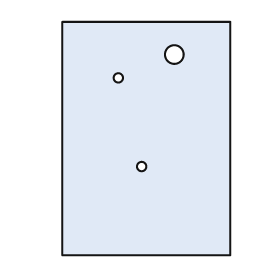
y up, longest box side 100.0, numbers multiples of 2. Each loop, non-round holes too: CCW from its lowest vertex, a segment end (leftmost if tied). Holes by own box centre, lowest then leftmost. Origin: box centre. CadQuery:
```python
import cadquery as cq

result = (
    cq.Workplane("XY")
    .moveTo(-36.0, -50.0)
    .lineTo(36.0, -50.0)
    .lineTo(36.0, 50.0)
    .lineTo(-36.0, 50.0)
    .close()
    .moveTo(-2.0, -12.0)
    .circle(2.0)
    .moveTo(-12.0, 26.0)
    .circle(2.0)
    .moveTo(12.0, 36.0)
    .circle(4.0)
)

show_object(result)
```